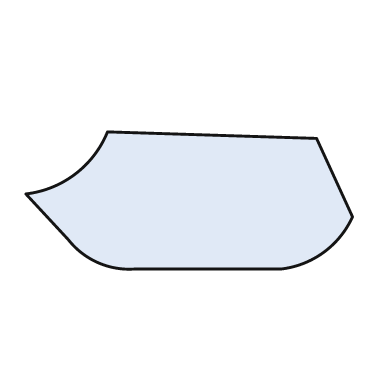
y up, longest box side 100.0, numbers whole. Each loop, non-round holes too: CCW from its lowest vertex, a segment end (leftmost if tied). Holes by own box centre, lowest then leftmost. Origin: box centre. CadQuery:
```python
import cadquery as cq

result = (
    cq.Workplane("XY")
    .moveTo(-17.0, -21.0)
    .lineTo(28.0, -21.0)
    .threePointArc((41.0, -16.0), (50.0, -5.0))
    .lineTo(39.0, 19.0)
    .lineTo(-25.0, 21.0)
    .threePointArc((-35.0, 8.0), (-50.0, 2.0))
    .lineTo(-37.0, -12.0)
    .threePointArc((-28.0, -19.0), (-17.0, -21.0))
    .close()
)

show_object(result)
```